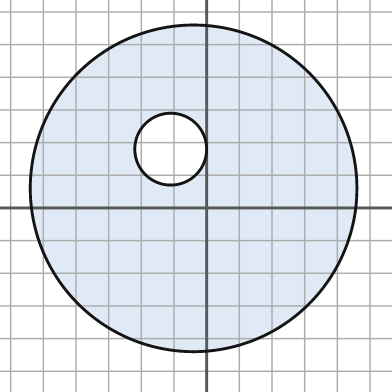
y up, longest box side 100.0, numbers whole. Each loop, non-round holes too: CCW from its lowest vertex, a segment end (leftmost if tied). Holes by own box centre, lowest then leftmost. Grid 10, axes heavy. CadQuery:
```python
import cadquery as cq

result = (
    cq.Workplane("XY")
    .moveTo(-4.0, 6.0)
    .circle(50.0)
    .moveTo(-11.0, 18.0)
    .circle(11.0)
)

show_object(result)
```